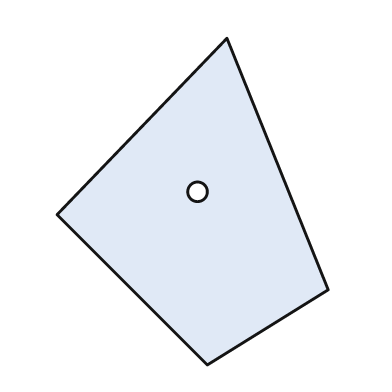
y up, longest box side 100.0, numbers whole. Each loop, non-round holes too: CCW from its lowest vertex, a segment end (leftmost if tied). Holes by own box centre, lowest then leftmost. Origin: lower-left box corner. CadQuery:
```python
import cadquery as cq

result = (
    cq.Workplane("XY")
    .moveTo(46.0, 0.0)
    .lineTo(83.0, 23.0)
    .lineTo(52.0, 100.0)
    .lineTo(0.0, 46.0)
    .close()
    .moveTo(43.0, 53.0)
    .circle(3.0)
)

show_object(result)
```